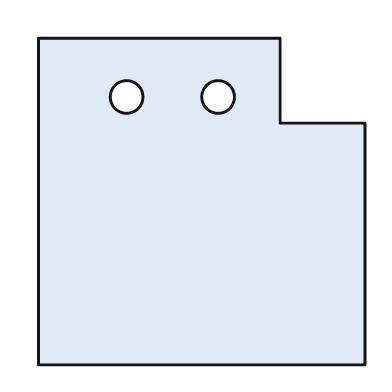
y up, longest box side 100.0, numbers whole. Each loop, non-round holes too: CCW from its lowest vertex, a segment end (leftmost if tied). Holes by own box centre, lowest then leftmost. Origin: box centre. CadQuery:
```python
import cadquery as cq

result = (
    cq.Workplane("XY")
    .moveTo(-50.0, -50.0)
    .lineTo(50.0, -50.0)
    .lineTo(50.0, 24.0)
    .lineTo(24.0, 24.0)
    .lineTo(24.0, 50.0)
    .lineTo(-50.0, 50.0)
    .close()
    .moveTo(-23.0, 32.0)
    .circle(5.0)
    .moveTo(5.0, 32.0)
    .circle(5.0)
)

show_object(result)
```